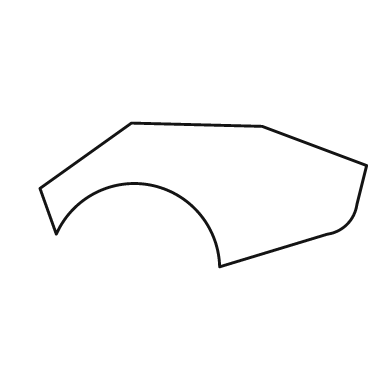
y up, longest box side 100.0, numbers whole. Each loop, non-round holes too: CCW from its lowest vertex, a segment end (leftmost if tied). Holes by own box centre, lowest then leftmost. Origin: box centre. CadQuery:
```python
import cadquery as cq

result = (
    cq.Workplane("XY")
    .moveTo(5.0, -22.0)
    .lineTo(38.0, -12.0)
    .threePointArc((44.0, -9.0), (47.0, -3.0))
    .lineTo(50.0, 9.0)
    .lineTo(18.0, 21.0)
    .lineTo(-22.0, 22.0)
    .lineTo(-50.0, 2.0)
    .lineTo(-45.0, -12.0)
    .threePointArc((-16.0, 3.0), (5.0, -22.0))
    .close()
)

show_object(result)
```